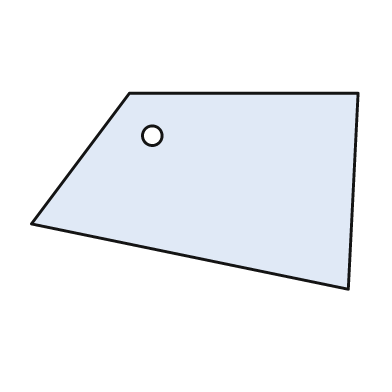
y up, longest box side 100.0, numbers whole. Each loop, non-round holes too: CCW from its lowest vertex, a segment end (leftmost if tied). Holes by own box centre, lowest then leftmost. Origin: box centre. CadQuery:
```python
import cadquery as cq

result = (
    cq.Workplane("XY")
    .moveTo(47.0, -30.0)
    .lineTo(50.0, 30.0)
    .lineTo(-20.0, 30.0)
    .lineTo(-50.0, -10.0)
    .close()
    .moveTo(-13.0, 17.0)
    .circle(3.0)
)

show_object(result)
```